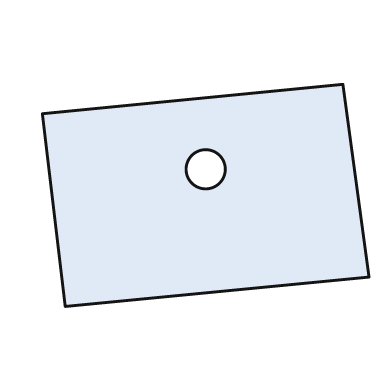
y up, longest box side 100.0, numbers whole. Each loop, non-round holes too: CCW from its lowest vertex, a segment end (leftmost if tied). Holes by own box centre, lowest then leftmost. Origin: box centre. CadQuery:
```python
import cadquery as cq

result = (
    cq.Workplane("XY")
    .moveTo(-43.0, -34.0)
    .lineTo(50.0, -25.0)
    .lineTo(42.0, 34.0)
    .lineTo(-50.0, 25.0)
    .close()
    .moveTo(0.0, 8.0)
    .circle(6.0)
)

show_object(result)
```